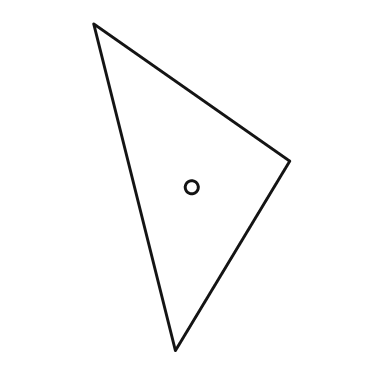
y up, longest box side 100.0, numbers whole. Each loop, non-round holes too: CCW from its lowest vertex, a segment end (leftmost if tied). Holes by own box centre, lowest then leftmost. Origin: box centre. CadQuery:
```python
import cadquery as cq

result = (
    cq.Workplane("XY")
    .moveTo(-5.0, -50.0)
    .lineTo(30.0, 8.0)
    .lineTo(-30.0, 50.0)
    .close()
    .moveTo(0.0, 0.0)
    .circle(2.0)
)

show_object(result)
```